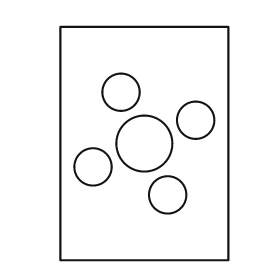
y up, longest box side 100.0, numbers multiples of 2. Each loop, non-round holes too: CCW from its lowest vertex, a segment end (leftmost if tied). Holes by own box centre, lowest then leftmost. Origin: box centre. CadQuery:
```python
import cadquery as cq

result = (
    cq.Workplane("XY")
    .moveTo(-36.0, -50.0)
    .lineTo(36.0, -50.0)
    .lineTo(36.0, 50.0)
    .lineTo(-36.0, 50.0)
    .close()
    .moveTo(10.0, -22.0)
    .circle(8.0)
    .moveTo(-22.0, -10.0)
    .circle(8.0)
    .moveTo(0.0, 0.0)
    .circle(12.0)
    .moveTo(22.0, 10.0)
    .circle(8.0)
    .moveTo(-10.0, 22.0)
    .circle(8.0)
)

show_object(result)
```